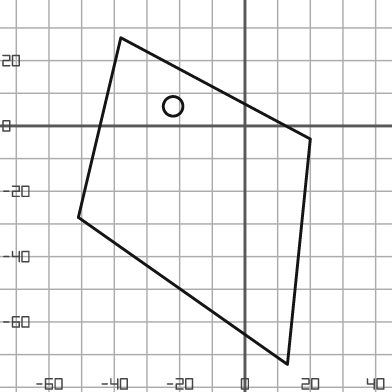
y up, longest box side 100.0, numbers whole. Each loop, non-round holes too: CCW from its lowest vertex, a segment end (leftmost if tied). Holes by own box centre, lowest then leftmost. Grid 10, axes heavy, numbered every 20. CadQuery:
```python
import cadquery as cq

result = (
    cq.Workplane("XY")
    .moveTo(13.0, -73.0)
    .lineTo(20.0, -4.0)
    .lineTo(-38.0, 27.0)
    .lineTo(-51.0, -28.0)
    .close()
    .moveTo(-22.0, 6.0)
    .circle(3.0)
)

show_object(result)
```